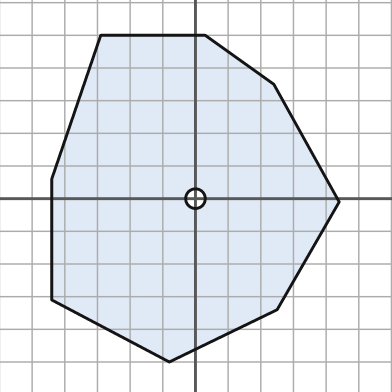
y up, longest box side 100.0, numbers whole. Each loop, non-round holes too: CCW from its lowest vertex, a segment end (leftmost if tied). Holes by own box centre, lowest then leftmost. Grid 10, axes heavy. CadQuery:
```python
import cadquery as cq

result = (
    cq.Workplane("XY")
    .moveTo(-8.0, -50.0)
    .lineTo(25.0, -34.0)
    .lineTo(44.0, -1.0)
    .lineTo(24.0, 35.0)
    .lineTo(3.0, 50.0)
    .lineTo(-29.0, 50.0)
    .lineTo(-44.0, 6.0)
    .lineTo(-44.0, -31.0)
    .close()
    .moveTo(0.0, 0.0)
    .circle(3.0)
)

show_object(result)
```